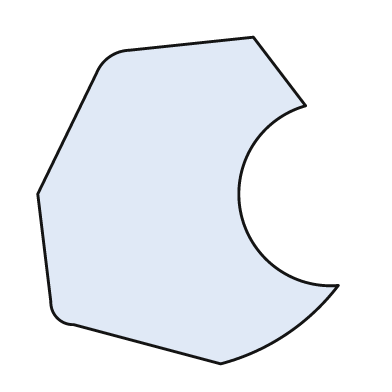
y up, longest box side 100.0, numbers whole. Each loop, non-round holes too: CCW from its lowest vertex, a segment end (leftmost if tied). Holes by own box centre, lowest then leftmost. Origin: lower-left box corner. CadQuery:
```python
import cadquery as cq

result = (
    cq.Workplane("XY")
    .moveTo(56.0, 0.0)
    .threePointArc((76.0, 9.0), (92.0, 24.0))
    .threePointArc((62.0, 47.0), (82.0, 79.0))
    .lineTo(66.0, 100.0)
    .lineTo(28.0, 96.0)
    .threePointArc((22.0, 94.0), (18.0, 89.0))
    .lineTo(0.0, 52.0)
    .lineTo(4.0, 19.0)
    .threePointArc((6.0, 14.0), (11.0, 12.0))
    .close()
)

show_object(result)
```